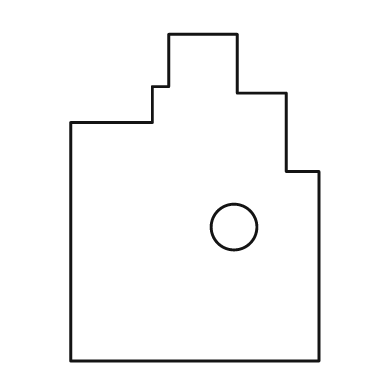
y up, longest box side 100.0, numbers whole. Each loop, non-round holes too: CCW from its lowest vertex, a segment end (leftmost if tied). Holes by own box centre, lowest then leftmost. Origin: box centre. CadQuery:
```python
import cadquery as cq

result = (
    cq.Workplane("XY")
    .moveTo(-38.0, -50.0)
    .lineTo(38.0, -50.0)
    .lineTo(38.0, 8.0)
    .lineTo(28.0, 8.0)
    .lineTo(28.0, 32.0)
    .lineTo(13.0, 32.0)
    .lineTo(13.0, 50.0)
    .lineTo(-8.0, 50.0)
    .lineTo(-8.0, 34.0)
    .lineTo(-13.0, 34.0)
    .lineTo(-13.0, 23.0)
    .lineTo(-38.0, 23.0)
    .close()
    .moveTo(12.0, -9.0)
    .circle(7.0)
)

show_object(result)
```